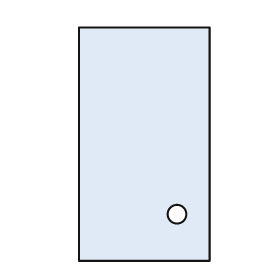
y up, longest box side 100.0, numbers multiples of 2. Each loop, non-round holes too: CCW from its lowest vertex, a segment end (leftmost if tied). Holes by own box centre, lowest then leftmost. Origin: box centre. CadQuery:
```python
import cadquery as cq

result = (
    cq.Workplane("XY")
    .moveTo(-28.0, -50.0)
    .lineTo(28.0, -50.0)
    .lineTo(28.0, 50.0)
    .lineTo(-28.0, 50.0)
    .close()
    .moveTo(14.0, -30.0)
    .circle(4.0)
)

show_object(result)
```